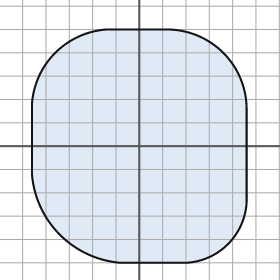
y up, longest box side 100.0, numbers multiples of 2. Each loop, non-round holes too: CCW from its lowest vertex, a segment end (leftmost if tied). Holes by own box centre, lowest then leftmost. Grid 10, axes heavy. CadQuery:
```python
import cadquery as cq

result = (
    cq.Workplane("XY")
    .moveTo(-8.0, -50.0)
    .lineTo(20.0, -50.0)
    .threePointArc((38.0, -42.0), (46.0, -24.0))
    .lineTo(46.0, 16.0)
    .threePointArc((36.0, 40.0), (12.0, 50.0))
    .lineTo(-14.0, 50.0)
    .threePointArc((-36.0, 40.0), (-46.0, 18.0))
    .lineTo(-46.0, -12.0)
    .threePointArc((-34.0, -38.0), (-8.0, -50.0))
    .close()
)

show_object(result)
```